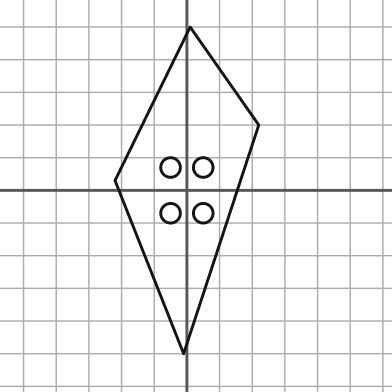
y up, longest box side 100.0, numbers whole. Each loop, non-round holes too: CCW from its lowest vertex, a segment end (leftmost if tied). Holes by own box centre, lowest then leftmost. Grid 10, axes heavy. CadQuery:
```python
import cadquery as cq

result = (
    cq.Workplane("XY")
    .moveTo(-1.0, -50.0)
    .lineTo(22.0, 20.0)
    .lineTo(1.0, 50.0)
    .lineTo(-22.0, 3.0)
    .close()
    .moveTo(-5.0, -7.0)
    .circle(3.0)
    .moveTo(5.0, -7.0)
    .circle(3.0)
    .moveTo(-5.0, 7.0)
    .circle(3.0)
    .moveTo(5.0, 7.0)
    .circle(3.0)
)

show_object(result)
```